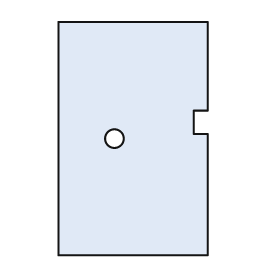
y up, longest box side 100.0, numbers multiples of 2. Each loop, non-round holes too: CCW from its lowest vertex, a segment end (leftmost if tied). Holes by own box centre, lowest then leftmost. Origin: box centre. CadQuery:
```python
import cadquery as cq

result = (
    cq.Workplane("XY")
    .moveTo(-32.0, -50.0)
    .lineTo(32.0, -50.0)
    .lineTo(32.0, 2.0)
    .lineTo(26.0, 2.0)
    .lineTo(26.0, 12.0)
    .lineTo(32.0, 12.0)
    .lineTo(32.0, 50.0)
    .lineTo(-32.0, 50.0)
    .close()
    .moveTo(-8.0, 0.0)
    .circle(4.0)
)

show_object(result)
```